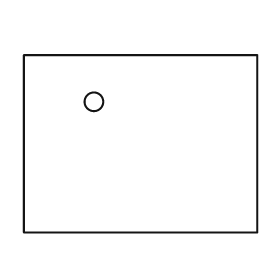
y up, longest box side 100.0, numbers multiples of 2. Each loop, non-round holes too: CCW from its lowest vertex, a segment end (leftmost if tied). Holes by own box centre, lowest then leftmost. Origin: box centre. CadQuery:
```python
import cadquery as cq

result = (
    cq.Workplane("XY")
    .moveTo(-50.0, -38.0)
    .lineTo(50.0, -38.0)
    .lineTo(50.0, 38.0)
    .lineTo(-50.0, 38.0)
    .close()
    .moveTo(-20.0, 18.0)
    .circle(4.0)
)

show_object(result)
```